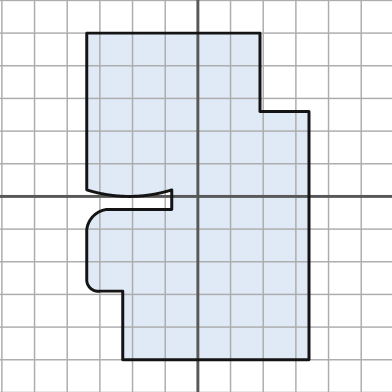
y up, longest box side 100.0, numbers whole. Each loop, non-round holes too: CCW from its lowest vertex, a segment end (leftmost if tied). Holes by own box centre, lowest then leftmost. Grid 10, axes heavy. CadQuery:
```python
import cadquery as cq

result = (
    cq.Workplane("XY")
    .moveTo(-23.0, -50.0)
    .lineTo(34.0, -50.0)
    .lineTo(34.0, 26.0)
    .lineTo(19.0, 26.0)
    .lineTo(19.0, 50.0)
    .lineTo(-34.0, 50.0)
    .lineTo(-34.0, 2.0)
    .threePointArc((-21.0, 0.0), (-8.0, 2.0))
    .lineTo(-8.0, -4.0)
    .lineTo(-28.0, -4.0)
    .threePointArc((-32.0, -6.0), (-34.0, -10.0))
    .lineTo(-34.0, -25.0)
    .threePointArc((-33.0, -28.0), (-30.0, -29.0))
    .lineTo(-23.0, -29.0)
    .close()
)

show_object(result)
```